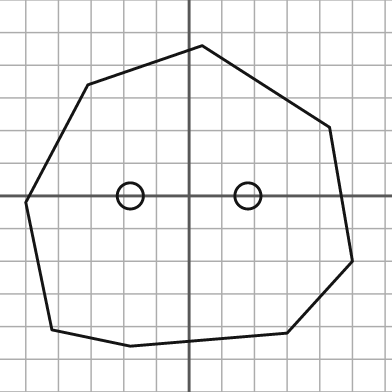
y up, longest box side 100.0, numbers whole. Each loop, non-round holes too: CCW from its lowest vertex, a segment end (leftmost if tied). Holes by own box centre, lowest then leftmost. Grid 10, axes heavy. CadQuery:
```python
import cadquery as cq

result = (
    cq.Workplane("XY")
    .moveTo(-18.0, -46.0)
    .lineTo(30.0, -42.0)
    .lineTo(50.0, -20.0)
    .lineTo(43.0, 21.0)
    .lineTo(4.0, 46.0)
    .lineTo(-31.0, 34.0)
    .lineTo(-50.0, -2.0)
    .lineTo(-42.0, -41.0)
    .close()
    .moveTo(-18.0, 0.0)
    .circle(4.0)
    .moveTo(18.0, 0.0)
    .circle(4.0)
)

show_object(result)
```